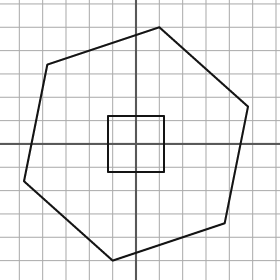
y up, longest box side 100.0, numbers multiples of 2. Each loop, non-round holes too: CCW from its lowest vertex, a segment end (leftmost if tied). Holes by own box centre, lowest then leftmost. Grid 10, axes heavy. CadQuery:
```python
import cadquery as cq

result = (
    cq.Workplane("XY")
    .moveTo(-10.0, -50.0)
    .lineTo(38.0, -34.0)
    .lineTo(48.0, 16.0)
    .lineTo(10.0, 50.0)
    .lineTo(-38.0, 34.0)
    .lineTo(-48.0, -16.0)
    .close()
    .moveTo(-12.0, -12.0)
    .lineTo(12.0, -12.0)
    .lineTo(12.0, 12.0)
    .lineTo(-12.0, 12.0)
    .close()
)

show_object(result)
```